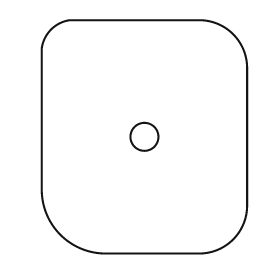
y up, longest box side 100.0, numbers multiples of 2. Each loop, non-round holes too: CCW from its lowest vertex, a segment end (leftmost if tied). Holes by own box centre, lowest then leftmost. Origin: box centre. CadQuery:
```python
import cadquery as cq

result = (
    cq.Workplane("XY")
    .moveTo(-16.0, -50.0)
    .lineTo(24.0, -50.0)
    .threePointArc((38.0, -44.0), (44.0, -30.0))
    .lineTo(44.0, 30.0)
    .threePointArc((38.0, 44.0), (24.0, 50.0))
    .lineTo(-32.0, 50.0)
    .threePointArc((-40.0, 46.0), (-44.0, 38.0))
    .lineTo(-44.0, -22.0)
    .threePointArc((-36.0, -42.0), (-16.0, -50.0))
    .close()
    .moveTo(0.0, 0.0)
    .circle(6.0)
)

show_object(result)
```